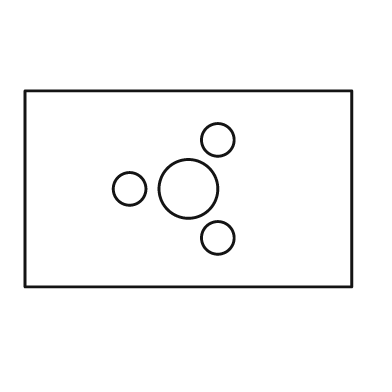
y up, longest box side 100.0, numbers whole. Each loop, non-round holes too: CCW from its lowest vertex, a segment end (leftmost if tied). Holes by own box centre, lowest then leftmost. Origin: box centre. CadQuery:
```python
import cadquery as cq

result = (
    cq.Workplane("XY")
    .moveTo(-50.0, -30.0)
    .lineTo(50.0, -30.0)
    .lineTo(50.0, 30.0)
    .lineTo(-50.0, 30.0)
    .close()
    .moveTo(9.0, -15.0)
    .circle(5.0)
    .moveTo(-18.0, 0.0)
    .circle(5.0)
    .moveTo(0.0, 0.0)
    .circle(9.0)
    .moveTo(9.0, 15.0)
    .circle(5.0)
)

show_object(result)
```